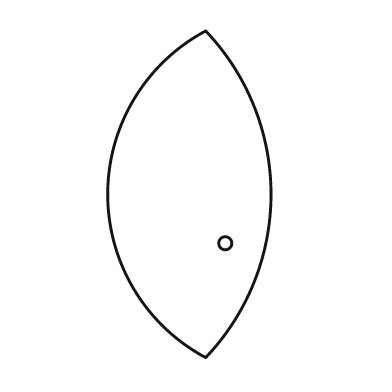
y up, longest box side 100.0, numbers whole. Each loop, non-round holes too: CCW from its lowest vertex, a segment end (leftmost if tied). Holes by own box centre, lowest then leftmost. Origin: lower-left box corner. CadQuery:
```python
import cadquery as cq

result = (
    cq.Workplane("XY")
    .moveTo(30.0, 0.0)
    .threePointArc((50.0, 50.0), (30.0, 100.0))
    .threePointArc((0.0, 50.0), (30.0, 0.0))
    .close()
    .moveTo(36.0, 35.0)
    .circle(2.0)
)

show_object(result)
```